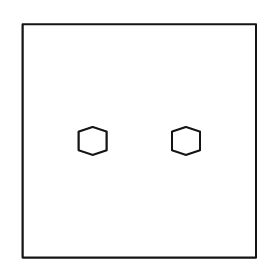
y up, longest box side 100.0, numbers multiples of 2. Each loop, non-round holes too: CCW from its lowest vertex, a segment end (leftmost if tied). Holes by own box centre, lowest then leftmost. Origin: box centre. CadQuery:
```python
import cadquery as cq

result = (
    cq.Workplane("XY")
    .moveTo(-50.0, -50.0)
    .lineTo(50.0, -50.0)
    .lineTo(50.0, 50.0)
    .lineTo(-50.0, 50.0)
    .close()
    .moveTo(-20.0, -6.0)
    .lineTo(-14.0, -4.0)
    .lineTo(-14.0, 4.0)
    .lineTo(-20.0, 6.0)
    .lineTo(-26.0, 4.0)
    .lineTo(-26.0, -4.0)
    .close()
    .moveTo(20.0, -6.0)
    .lineTo(26.0, -4.0)
    .lineTo(26.0, 4.0)
    .lineTo(20.0, 6.0)
    .lineTo(14.0, 4.0)
    .lineTo(14.0, -4.0)
    .close()
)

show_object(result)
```